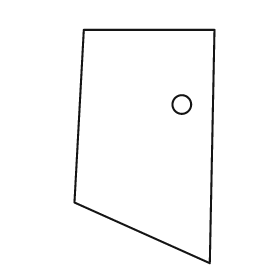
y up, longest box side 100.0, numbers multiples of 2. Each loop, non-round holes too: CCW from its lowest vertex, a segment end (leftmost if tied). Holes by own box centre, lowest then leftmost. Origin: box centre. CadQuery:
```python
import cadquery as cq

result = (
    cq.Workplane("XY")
    .moveTo(28.0, -50.0)
    .lineTo(30.0, 50.0)
    .lineTo(-26.0, 50.0)
    .lineTo(-30.0, -24.0)
    .close()
    .moveTo(16.0, 18.0)
    .circle(4.0)
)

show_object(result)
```